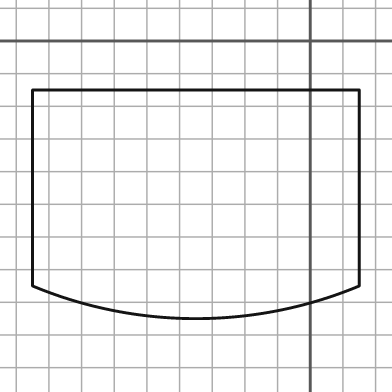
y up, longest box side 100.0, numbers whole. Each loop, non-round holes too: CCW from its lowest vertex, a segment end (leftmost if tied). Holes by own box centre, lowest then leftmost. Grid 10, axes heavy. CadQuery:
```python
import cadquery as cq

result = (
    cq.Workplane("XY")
    .moveTo(-85.0, -75.0)
    .threePointArc((-35.0, -85.0), (15.0, -75.0))
    .lineTo(15.0, -15.0)
    .lineTo(-85.0, -15.0)
    .close()
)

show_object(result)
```